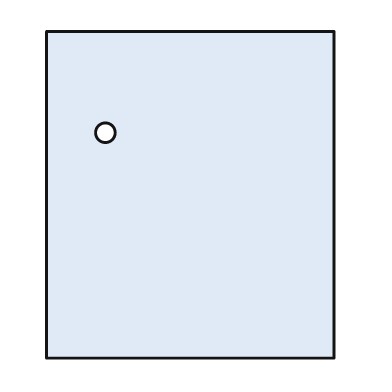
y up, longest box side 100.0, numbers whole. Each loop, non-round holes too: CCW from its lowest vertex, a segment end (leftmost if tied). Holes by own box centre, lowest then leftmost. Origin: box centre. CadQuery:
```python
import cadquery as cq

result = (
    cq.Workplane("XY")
    .moveTo(-44.0, -50.0)
    .lineTo(44.0, -50.0)
    .lineTo(44.0, 50.0)
    .lineTo(-44.0, 50.0)
    .close()
    .moveTo(-26.0, 19.0)
    .circle(3.0)
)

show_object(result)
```